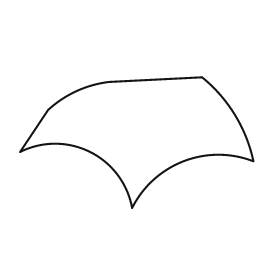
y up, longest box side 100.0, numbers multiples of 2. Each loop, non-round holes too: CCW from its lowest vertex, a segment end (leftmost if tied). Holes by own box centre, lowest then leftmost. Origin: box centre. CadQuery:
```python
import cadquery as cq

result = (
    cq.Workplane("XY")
    .moveTo(-2.0, -28.0)
    .threePointArc((20.0, -8.0), (50.0, -8.0))
    .threePointArc((42.0, 12.0), (28.0, 28.0))
    .lineTo(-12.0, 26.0)
    .threePointArc((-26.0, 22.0), (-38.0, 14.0))
    .lineTo(-50.0, -4.0)
    .threePointArc((-20.0, -4.0), (-2.0, -28.0))
    .close()
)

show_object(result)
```